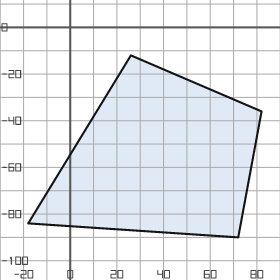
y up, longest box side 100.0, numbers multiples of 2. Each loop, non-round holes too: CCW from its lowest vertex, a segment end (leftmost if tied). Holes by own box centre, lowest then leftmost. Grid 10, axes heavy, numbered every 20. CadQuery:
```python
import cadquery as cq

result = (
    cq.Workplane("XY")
    .moveTo(72.0, -90.0)
    .lineTo(82.0, -36.0)
    .lineTo(26.0, -12.0)
    .lineTo(-18.0, -84.0)
    .close()
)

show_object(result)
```